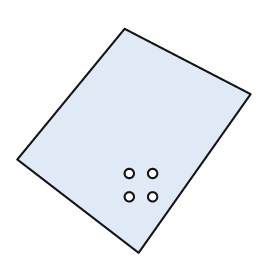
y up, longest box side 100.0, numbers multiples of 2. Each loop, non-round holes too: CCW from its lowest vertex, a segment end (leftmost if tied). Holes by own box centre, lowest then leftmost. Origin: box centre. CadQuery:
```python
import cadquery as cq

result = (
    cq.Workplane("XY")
    .moveTo(2.0, -48.0)
    .lineTo(50.0, 20.0)
    .lineTo(-4.0, 48.0)
    .lineTo(-50.0, -8.0)
    .close()
    .moveTo(-2.0, -24.0)
    .circle(2.0)
    .moveTo(8.0, -24.0)
    .circle(2.0)
    .moveTo(-2.0, -14.0)
    .circle(2.0)
    .moveTo(8.0, -14.0)
    .circle(2.0)
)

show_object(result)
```